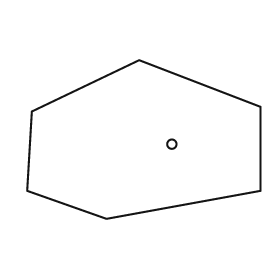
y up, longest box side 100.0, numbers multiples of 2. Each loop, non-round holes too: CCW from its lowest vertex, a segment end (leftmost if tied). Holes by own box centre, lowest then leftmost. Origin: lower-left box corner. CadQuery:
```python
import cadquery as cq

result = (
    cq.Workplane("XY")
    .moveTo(34.0, 0.0)
    .lineTo(100.0, 12.0)
    .lineTo(100.0, 48.0)
    .lineTo(48.0, 68.0)
    .lineTo(2.0, 46.0)
    .lineTo(0.0, 12.0)
    .close()
    .moveTo(62.0, 32.0)
    .circle(2.0)
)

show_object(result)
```